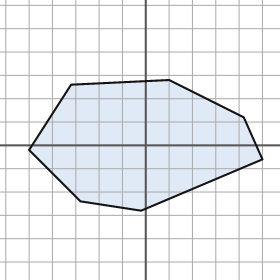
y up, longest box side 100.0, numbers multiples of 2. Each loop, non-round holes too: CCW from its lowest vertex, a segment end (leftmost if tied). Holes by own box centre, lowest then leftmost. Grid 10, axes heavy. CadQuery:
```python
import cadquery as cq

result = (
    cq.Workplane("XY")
    .moveTo(-2.0, -28.0)
    .lineTo(50.0, -6.0)
    .lineTo(42.0, 12.0)
    .lineTo(10.0, 28.0)
    .lineTo(-32.0, 26.0)
    .lineTo(-50.0, -2.0)
    .lineTo(-28.0, -24.0)
    .close()
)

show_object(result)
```